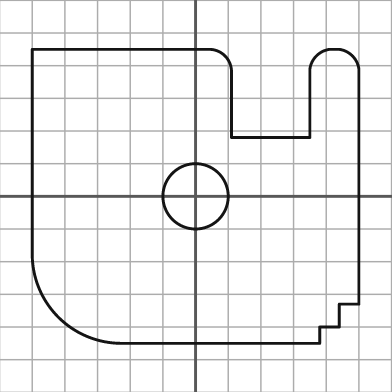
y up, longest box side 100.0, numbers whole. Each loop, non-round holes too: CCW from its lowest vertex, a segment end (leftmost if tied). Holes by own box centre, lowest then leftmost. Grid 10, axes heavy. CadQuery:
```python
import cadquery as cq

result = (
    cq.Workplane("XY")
    .moveTo(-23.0, -45.0)
    .lineTo(38.0, -45.0)
    .lineTo(38.0, -40.0)
    .lineTo(44.0, -40.0)
    .lineTo(44.0, -33.0)
    .lineTo(50.0, -33.0)
    .lineTo(50.0, 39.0)
    .threePointArc((48.0, 43.0), (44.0, 45.0))
    .lineTo(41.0, 45.0)
    .threePointArc((37.0, 43.0), (35.0, 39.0))
    .lineTo(35.0, 18.0)
    .lineTo(11.0, 18.0)
    .lineTo(11.0, 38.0)
    .threePointArc((9.0, 43.0), (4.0, 45.0))
    .lineTo(-50.0, 45.0)
    .lineTo(-50.0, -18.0)
    .threePointArc((-42.0, -37.0), (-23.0, -45.0))
    .close()
    .moveTo(0.0, 0.0)
    .circle(10.0)
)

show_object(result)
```